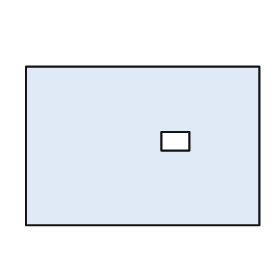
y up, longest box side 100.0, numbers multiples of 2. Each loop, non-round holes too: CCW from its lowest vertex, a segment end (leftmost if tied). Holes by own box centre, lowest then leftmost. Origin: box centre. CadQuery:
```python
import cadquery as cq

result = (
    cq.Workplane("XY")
    .moveTo(-50.0, -34.0)
    .lineTo(50.0, -34.0)
    .lineTo(50.0, 34.0)
    .lineTo(-50.0, 34.0)
    .close()
    .moveTo(8.0, -2.0)
    .lineTo(20.0, -2.0)
    .lineTo(20.0, 6.0)
    .lineTo(8.0, 6.0)
    .close()
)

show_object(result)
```